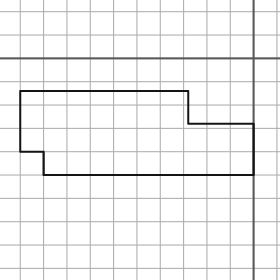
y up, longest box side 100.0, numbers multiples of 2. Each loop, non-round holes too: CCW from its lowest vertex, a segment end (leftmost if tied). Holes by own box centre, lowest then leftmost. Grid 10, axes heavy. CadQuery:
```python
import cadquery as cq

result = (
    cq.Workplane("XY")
    .moveTo(-90.0, -50.0)
    .lineTo(0.0, -50.0)
    .lineTo(0.0, -28.0)
    .lineTo(-28.0, -28.0)
    .lineTo(-28.0, -14.0)
    .lineTo(-100.0, -14.0)
    .lineTo(-100.0, -40.0)
    .lineTo(-90.0, -40.0)
    .close()
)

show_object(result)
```